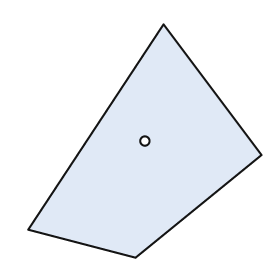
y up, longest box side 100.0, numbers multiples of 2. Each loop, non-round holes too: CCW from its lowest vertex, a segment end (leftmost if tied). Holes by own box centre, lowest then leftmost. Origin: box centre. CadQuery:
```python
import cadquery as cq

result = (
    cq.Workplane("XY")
    .moveTo(-4.0, -50.0)
    .lineTo(50.0, -6.0)
    .lineTo(8.0, 50.0)
    .lineTo(-50.0, -38.0)
    .close()
    .moveTo(0.0, 0.0)
    .circle(2.0)
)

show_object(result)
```